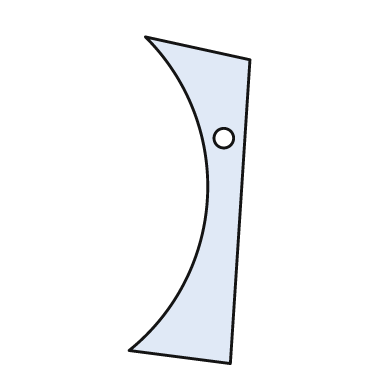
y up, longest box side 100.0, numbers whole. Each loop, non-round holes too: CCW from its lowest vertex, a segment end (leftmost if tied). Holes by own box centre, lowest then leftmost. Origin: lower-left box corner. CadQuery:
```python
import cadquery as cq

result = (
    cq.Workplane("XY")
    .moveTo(31.0, 0.0)
    .lineTo(37.0, 93.0)
    .lineTo(5.0, 100.0)
    .threePointArc((24.0, 51.0), (0.0, 4.0))
    .close()
    .moveTo(29.0, 69.0)
    .circle(3.0)
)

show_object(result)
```